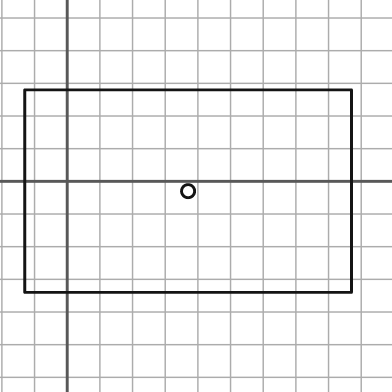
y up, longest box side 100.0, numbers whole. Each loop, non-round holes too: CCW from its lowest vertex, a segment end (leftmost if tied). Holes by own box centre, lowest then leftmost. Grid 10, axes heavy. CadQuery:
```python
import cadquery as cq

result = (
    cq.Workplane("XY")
    .moveTo(-13.0, -34.0)
    .lineTo(87.0, -34.0)
    .lineTo(87.0, 28.0)
    .lineTo(-13.0, 28.0)
    .close()
    .moveTo(37.0, -3.0)
    .circle(2.0)
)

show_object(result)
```